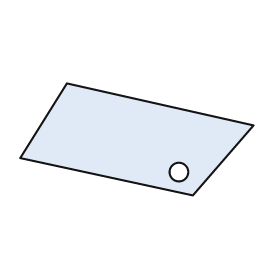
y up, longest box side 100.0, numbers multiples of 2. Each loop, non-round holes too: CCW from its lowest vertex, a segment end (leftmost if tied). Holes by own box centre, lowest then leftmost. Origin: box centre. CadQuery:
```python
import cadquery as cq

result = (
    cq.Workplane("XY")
    .moveTo(24.0, -24.0)
    .lineTo(50.0, 6.0)
    .lineTo(-30.0, 24.0)
    .lineTo(-50.0, -8.0)
    .close()
    .moveTo(18.0, -14.0)
    .circle(4.0)
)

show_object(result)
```